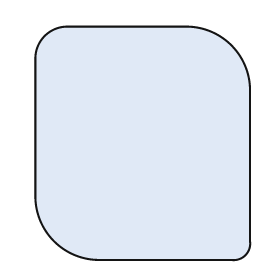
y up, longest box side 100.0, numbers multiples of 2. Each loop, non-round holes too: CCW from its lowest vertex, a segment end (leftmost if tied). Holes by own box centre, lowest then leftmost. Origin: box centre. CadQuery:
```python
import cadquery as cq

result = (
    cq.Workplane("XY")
    .moveTo(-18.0, -50.0)
    .lineTo(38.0, -50.0)
    .threePointArc((44.0, -48.0), (46.0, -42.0))
    .lineTo(46.0, 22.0)
    .threePointArc((38.0, 42.0), (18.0, 50.0))
    .lineTo(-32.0, 50.0)
    .threePointArc((-42.0, 46.0), (-46.0, 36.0))
    .lineTo(-46.0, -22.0)
    .threePointArc((-38.0, -42.0), (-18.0, -50.0))
    .close()
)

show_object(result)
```